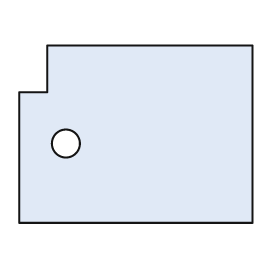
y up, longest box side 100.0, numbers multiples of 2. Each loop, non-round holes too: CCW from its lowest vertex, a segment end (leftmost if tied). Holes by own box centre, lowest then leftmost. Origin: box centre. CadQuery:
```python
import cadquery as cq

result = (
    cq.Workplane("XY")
    .moveTo(-50.0, -38.0)
    .lineTo(50.0, -38.0)
    .lineTo(50.0, 38.0)
    .lineTo(-38.0, 38.0)
    .lineTo(-38.0, 18.0)
    .lineTo(-50.0, 18.0)
    .close()
    .moveTo(-30.0, -4.0)
    .circle(6.0)
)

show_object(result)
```